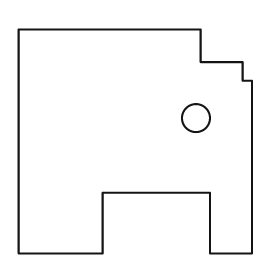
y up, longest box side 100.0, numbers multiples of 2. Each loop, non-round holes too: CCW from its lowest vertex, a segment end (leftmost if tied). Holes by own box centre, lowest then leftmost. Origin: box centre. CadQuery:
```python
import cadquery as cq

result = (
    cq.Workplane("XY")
    .moveTo(-50.0, -48.0)
    .lineTo(-14.0, -48.0)
    .lineTo(-14.0, -22.0)
    .lineTo(32.0, -22.0)
    .lineTo(32.0, -48.0)
    .lineTo(50.0, -48.0)
    .lineTo(50.0, 26.0)
    .lineTo(46.0, 26.0)
    .lineTo(46.0, 34.0)
    .lineTo(28.0, 34.0)
    .lineTo(28.0, 48.0)
    .lineTo(-50.0, 48.0)
    .close()
    .moveTo(26.0, 10.0)
    .circle(6.0)
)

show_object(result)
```